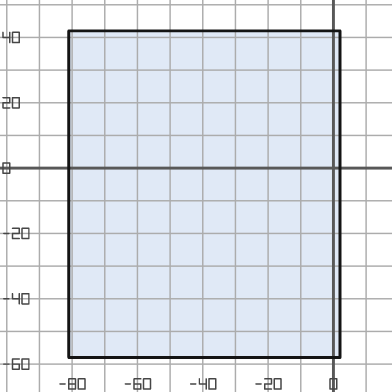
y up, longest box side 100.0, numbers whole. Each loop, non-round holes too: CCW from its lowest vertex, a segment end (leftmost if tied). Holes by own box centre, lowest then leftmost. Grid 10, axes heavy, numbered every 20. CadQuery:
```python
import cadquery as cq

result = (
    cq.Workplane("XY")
    .moveTo(-81.0, -58.0)
    .lineTo(2.0, -58.0)
    .lineTo(2.0, 42.0)
    .lineTo(-81.0, 42.0)
    .close()
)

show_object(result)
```